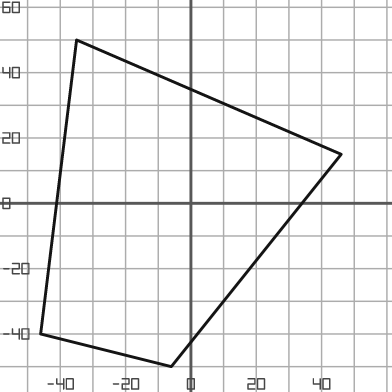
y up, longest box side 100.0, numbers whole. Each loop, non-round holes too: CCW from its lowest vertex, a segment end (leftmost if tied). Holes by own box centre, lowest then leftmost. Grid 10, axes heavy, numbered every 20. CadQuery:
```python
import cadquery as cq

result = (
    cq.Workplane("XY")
    .moveTo(-6.0, -50.0)
    .lineTo(46.0, 15.0)
    .lineTo(-35.0, 50.0)
    .lineTo(-46.0, -40.0)
    .close()
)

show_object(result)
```